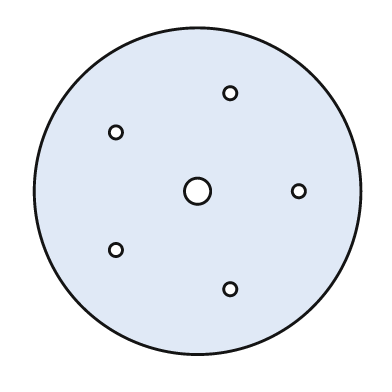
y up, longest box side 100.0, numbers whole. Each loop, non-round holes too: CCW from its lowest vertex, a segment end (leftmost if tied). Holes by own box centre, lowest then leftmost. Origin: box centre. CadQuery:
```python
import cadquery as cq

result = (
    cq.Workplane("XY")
    .moveTo(0.0, 0.0)
    .circle(50.0)
    .moveTo(10.0, -30.0)
    .circle(2.0)
    .moveTo(-25.0, -18.0)
    .circle(2.0)
    .moveTo(0.0, 0.0)
    .circle(4.0)
    .moveTo(31.0, 0.0)
    .circle(2.0)
    .moveTo(-25.0, 18.0)
    .circle(2.0)
    .moveTo(10.0, 30.0)
    .circle(2.0)
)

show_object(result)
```